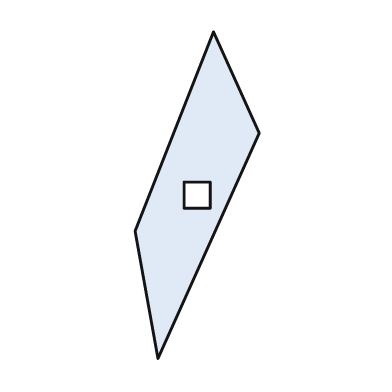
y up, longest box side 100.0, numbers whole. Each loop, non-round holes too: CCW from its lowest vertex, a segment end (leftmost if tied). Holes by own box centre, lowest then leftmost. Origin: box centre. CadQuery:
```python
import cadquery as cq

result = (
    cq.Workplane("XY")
    .moveTo(-12.0, -50.0)
    .lineTo(19.0, 19.0)
    .lineTo(5.0, 50.0)
    .lineTo(-19.0, -11.0)
    .close()
    .moveTo(-4.0, -4.0)
    .lineTo(4.0, -4.0)
    .lineTo(4.0, 4.0)
    .lineTo(-4.0, 4.0)
    .close()
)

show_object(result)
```